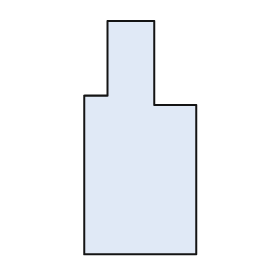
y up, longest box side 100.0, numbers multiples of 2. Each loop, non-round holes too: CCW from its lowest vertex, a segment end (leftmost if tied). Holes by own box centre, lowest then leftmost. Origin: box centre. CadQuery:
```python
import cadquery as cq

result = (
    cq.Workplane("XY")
    .moveTo(-24.0, -50.0)
    .lineTo(24.0, -50.0)
    .lineTo(24.0, 14.0)
    .lineTo(6.0, 14.0)
    .lineTo(6.0, 50.0)
    .lineTo(-14.0, 50.0)
    .lineTo(-14.0, 18.0)
    .lineTo(-24.0, 18.0)
    .close()
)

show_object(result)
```